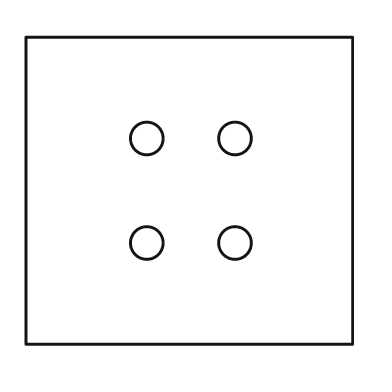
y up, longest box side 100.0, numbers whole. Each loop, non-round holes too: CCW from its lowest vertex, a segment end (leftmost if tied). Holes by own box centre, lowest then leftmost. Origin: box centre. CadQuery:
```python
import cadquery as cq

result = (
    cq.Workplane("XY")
    .moveTo(-50.0, -47.0)
    .lineTo(50.0, -47.0)
    .lineTo(50.0, 47.0)
    .lineTo(-50.0, 47.0)
    .close()
    .moveTo(-13.0, -16.0)
    .circle(5.0)
    .moveTo(14.0, -16.0)
    .circle(5.0)
    .moveTo(-13.0, 16.0)
    .circle(5.0)
    .moveTo(14.0, 16.0)
    .circle(5.0)
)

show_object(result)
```